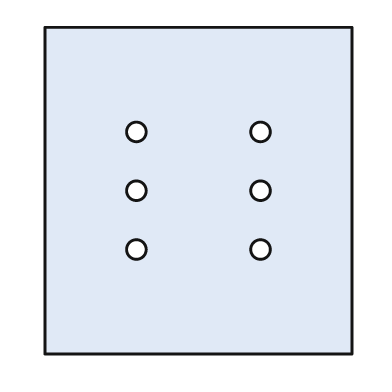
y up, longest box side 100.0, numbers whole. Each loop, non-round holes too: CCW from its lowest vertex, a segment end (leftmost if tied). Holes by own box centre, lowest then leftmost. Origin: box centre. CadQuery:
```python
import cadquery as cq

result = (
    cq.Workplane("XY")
    .moveTo(-47.0, -50.0)
    .lineTo(47.0, -50.0)
    .lineTo(47.0, 50.0)
    .lineTo(-47.0, 50.0)
    .close()
    .moveTo(-19.0, -18.0)
    .circle(3.0)
    .moveTo(19.0, -18.0)
    .circle(3.0)
    .moveTo(-19.0, 0.0)
    .circle(3.0)
    .moveTo(19.0, 0.0)
    .circle(3.0)
    .moveTo(-19.0, 18.0)
    .circle(3.0)
    .moveTo(19.0, 18.0)
    .circle(3.0)
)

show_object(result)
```